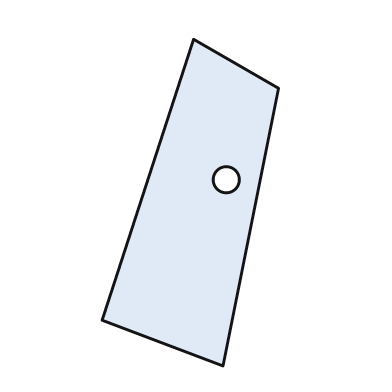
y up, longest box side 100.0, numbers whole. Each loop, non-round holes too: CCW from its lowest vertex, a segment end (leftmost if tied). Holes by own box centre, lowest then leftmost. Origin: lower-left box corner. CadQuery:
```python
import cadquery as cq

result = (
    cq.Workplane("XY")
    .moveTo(37.0, 0.0)
    .lineTo(54.0, 85.0)
    .lineTo(28.0, 100.0)
    .lineTo(0.0, 14.0)
    .close()
    .moveTo(38.0, 57.0)
    .circle(4.0)
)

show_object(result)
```